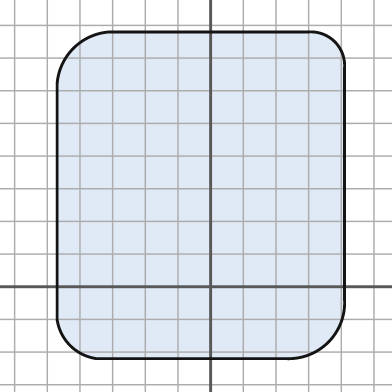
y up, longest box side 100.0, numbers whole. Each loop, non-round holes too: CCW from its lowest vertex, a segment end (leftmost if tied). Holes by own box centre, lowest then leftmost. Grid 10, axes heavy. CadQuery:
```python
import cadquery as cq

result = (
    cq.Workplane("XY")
    .moveTo(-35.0, -22.0)
    .lineTo(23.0, -22.0)
    .threePointArc((36.0, -17.0), (41.0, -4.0))
    .lineTo(41.0, 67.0)
    .threePointArc((38.0, 75.0), (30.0, 78.0))
    .lineTo(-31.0, 78.0)
    .threePointArc((-42.0, 73.0), (-47.0, 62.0))
    .lineTo(-47.0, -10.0)
    .threePointArc((-43.0, -18.0), (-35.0, -22.0))
    .close()
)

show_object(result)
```